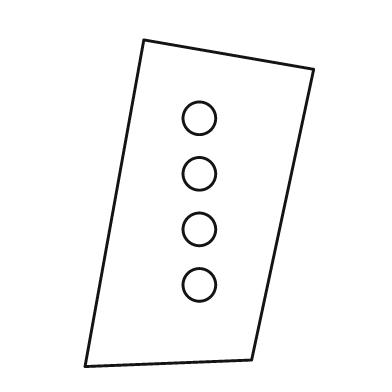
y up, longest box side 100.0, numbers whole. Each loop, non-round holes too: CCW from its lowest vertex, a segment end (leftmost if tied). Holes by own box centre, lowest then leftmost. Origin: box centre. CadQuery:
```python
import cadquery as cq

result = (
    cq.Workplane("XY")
    .moveTo(-35.0, -50.0)
    .lineTo(16.0, -48.0)
    .lineTo(35.0, 41.0)
    .lineTo(-17.0, 50.0)
    .close()
    .moveTo(0.0, -25.0)
    .circle(5.0)
    .moveTo(0.0, -8.0)
    .circle(5.0)
    .moveTo(0.0, 9.0)
    .circle(5.0)
    .moveTo(0.0, 26.0)
    .circle(5.0)
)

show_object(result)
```